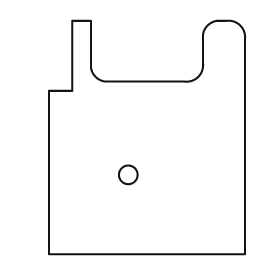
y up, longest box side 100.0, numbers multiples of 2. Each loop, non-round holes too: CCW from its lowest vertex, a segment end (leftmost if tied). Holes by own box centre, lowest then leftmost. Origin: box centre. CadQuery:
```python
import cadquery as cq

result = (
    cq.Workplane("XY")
    .moveTo(-42.0, -50.0)
    .lineTo(42.0, -50.0)
    .lineTo(42.0, 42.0)
    .threePointArc((40.0, 48.0), (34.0, 50.0))
    .lineTo(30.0, 50.0)
    .threePointArc((26.0, 48.0), (24.0, 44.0))
    .lineTo(24.0, 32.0)
    .threePointArc((22.0, 26.0), (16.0, 24.0))
    .lineTo(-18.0, 24.0)
    .threePointArc((-22.0, 26.0), (-24.0, 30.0))
    .lineTo(-24.0, 50.0)
    .lineTo(-32.0, 50.0)
    .lineTo(-32.0, 20.0)
    .lineTo(-42.0, 20.0)
    .close()
    .moveTo(-8.0, -16.0)
    .circle(4.0)
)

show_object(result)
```